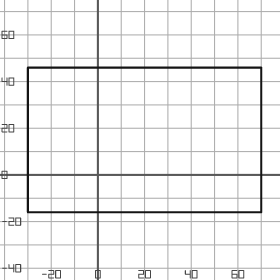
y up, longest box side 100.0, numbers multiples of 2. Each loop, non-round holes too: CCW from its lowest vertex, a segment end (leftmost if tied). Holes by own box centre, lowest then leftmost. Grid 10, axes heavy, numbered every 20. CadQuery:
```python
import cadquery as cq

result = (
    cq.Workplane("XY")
    .moveTo(-30.0, -16.0)
    .lineTo(70.0, -16.0)
    .lineTo(70.0, 46.0)
    .lineTo(-30.0, 46.0)
    .close()
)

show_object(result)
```